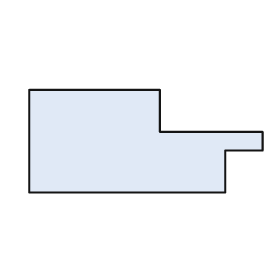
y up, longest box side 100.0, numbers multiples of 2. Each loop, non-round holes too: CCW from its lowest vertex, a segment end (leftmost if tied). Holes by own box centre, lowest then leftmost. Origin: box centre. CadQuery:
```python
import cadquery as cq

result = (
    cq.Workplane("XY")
    .moveTo(-50.0, -22.0)
    .lineTo(34.0, -22.0)
    .lineTo(34.0, -4.0)
    .lineTo(50.0, -4.0)
    .lineTo(50.0, 4.0)
    .lineTo(6.0, 4.0)
    .lineTo(6.0, 22.0)
    .lineTo(-50.0, 22.0)
    .close()
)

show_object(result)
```